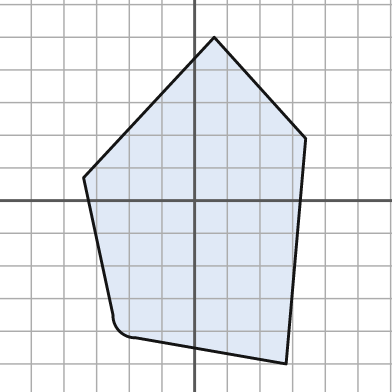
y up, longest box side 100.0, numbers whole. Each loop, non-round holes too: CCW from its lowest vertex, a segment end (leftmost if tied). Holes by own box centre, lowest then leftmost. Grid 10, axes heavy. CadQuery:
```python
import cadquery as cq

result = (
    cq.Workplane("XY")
    .moveTo(28.0, -50.0)
    .lineTo(34.0, 19.0)
    .lineTo(6.0, 50.0)
    .lineTo(-34.0, 7.0)
    .lineTo(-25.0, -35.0)
    .threePointArc((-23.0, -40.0), (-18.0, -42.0))
    .close()
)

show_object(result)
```